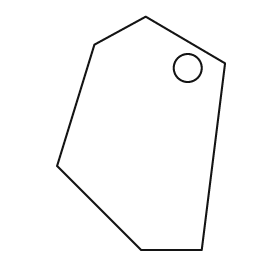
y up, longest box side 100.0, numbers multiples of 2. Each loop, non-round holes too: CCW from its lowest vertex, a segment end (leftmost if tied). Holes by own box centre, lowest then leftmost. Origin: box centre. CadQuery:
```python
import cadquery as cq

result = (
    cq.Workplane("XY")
    .moveTo(0.0, -50.0)
    .lineTo(26.0, -50.0)
    .lineTo(36.0, 30.0)
    .lineTo(2.0, 50.0)
    .lineTo(-20.0, 38.0)
    .lineTo(-36.0, -14.0)
    .close()
    .moveTo(20.0, 28.0)
    .circle(6.0)
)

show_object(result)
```